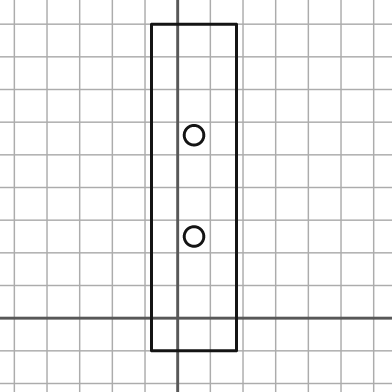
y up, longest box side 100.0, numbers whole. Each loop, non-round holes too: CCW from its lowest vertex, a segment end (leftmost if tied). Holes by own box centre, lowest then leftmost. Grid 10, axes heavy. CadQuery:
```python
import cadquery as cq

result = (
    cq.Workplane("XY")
    .moveTo(-8.0, -10.0)
    .lineTo(18.0, -10.0)
    .lineTo(18.0, 90.0)
    .lineTo(-8.0, 90.0)
    .close()
    .moveTo(5.0, 25.0)
    .circle(3.0)
    .moveTo(5.0, 56.0)
    .circle(3.0)
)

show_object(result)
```